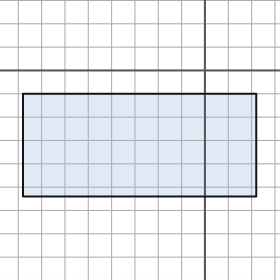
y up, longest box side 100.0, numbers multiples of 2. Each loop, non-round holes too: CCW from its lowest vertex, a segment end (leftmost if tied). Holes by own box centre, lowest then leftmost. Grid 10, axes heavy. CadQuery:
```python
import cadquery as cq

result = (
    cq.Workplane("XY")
    .moveTo(-78.0, -54.0)
    .lineTo(22.0, -54.0)
    .lineTo(22.0, -10.0)
    .lineTo(-78.0, -10.0)
    .close()
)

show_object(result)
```